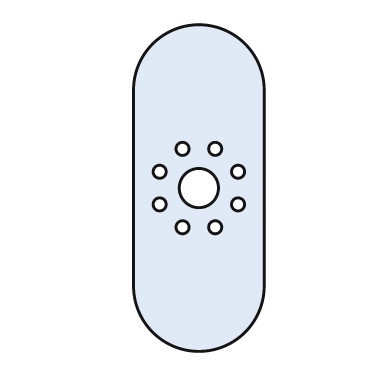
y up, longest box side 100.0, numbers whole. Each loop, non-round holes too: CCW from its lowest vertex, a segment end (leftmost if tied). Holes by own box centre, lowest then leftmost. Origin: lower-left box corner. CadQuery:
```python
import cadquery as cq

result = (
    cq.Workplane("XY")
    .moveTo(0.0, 20.0)
    .threePointArc((20.0, 0.0), (40.0, 20.0))
    .lineTo(40.0, 80.0)
    .threePointArc((20.0, 100.0), (0.0, 80.0))
    .close()
    .moveTo(15.0, 38.0)
    .circle(2.0)
    .moveTo(25.0, 38.0)
    .circle(2.0)
    .moveTo(8.0, 45.0)
    .circle(2.0)
    .moveTo(32.0, 45.0)
    .circle(2.0)
    .moveTo(20.0, 50.0)
    .circle(6.0)
    .moveTo(8.0, 55.0)
    .circle(2.0)
    .moveTo(32.0, 55.0)
    .circle(2.0)
    .moveTo(15.0, 62.0)
    .circle(2.0)
    .moveTo(25.0, 62.0)
    .circle(2.0)
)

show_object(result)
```